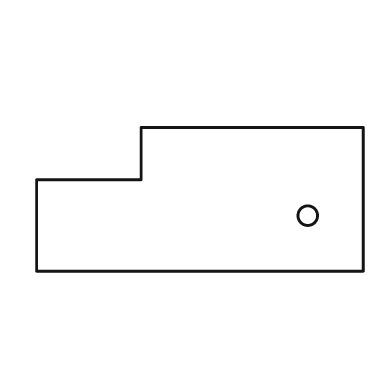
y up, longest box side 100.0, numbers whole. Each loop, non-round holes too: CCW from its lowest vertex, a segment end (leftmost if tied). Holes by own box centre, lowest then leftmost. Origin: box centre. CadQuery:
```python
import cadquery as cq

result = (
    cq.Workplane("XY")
    .moveTo(-50.0, -22.0)
    .lineTo(50.0, -22.0)
    .lineTo(50.0, 22.0)
    .lineTo(-18.0, 22.0)
    .lineTo(-18.0, 6.0)
    .lineTo(-50.0, 6.0)
    .close()
    .moveTo(33.0, -5.0)
    .circle(3.0)
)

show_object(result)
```